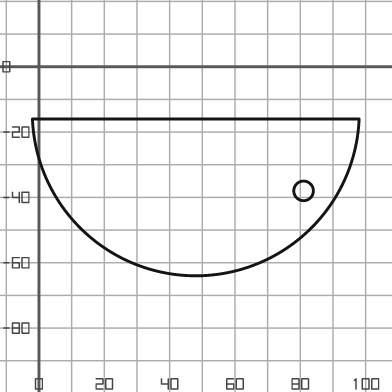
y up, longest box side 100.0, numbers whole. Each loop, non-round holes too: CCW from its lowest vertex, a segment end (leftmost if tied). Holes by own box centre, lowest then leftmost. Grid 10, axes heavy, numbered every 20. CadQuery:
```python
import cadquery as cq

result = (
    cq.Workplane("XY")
    .moveTo(-2.0, -16.0)
    .threePointArc((48.0, -64.0), (98.0, -16.0))
    .close()
    .moveTo(81.0, -38.0)
    .circle(3.0)
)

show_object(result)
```